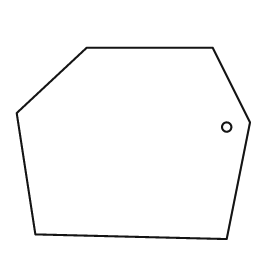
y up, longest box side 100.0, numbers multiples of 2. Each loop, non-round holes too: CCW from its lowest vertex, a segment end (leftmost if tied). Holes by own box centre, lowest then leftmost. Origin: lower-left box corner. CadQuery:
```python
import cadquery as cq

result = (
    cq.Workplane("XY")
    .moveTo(90.0, 0.0)
    .lineTo(100.0, 50.0)
    .lineTo(84.0, 82.0)
    .lineTo(30.0, 82.0)
    .lineTo(0.0, 54.0)
    .lineTo(8.0, 2.0)
    .close()
    .moveTo(90.0, 48.0)
    .circle(2.0)
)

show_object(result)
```